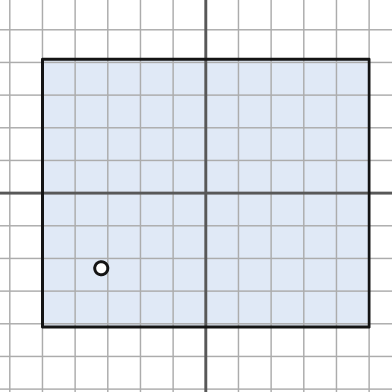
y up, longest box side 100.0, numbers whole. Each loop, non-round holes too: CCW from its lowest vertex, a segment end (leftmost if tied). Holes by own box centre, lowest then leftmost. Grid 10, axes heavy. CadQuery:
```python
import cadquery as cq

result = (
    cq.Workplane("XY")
    .moveTo(-50.0, -41.0)
    .lineTo(50.0, -41.0)
    .lineTo(50.0, 41.0)
    .lineTo(-50.0, 41.0)
    .close()
    .moveTo(-32.0, -23.0)
    .circle(2.0)
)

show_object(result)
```